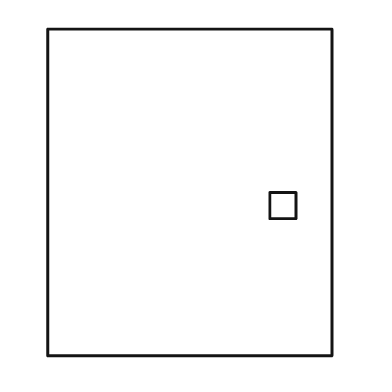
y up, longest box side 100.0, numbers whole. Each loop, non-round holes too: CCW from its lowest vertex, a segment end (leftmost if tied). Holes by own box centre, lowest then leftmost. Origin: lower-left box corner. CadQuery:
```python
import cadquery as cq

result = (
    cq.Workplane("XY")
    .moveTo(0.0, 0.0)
    .lineTo(87.0, 0.0)
    .lineTo(87.0, 100.0)
    .lineTo(0.0, 100.0)
    .close()
    .moveTo(68.0, 42.0)
    .lineTo(76.0, 42.0)
    .lineTo(76.0, 50.0)
    .lineTo(68.0, 50.0)
    .close()
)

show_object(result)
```